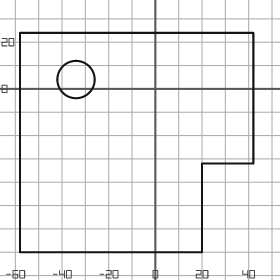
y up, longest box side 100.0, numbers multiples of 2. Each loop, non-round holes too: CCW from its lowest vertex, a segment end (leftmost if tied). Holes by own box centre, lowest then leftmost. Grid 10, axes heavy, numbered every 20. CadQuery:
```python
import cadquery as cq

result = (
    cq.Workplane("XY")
    .moveTo(-58.0, -70.0)
    .lineTo(20.0, -70.0)
    .lineTo(20.0, -32.0)
    .lineTo(42.0, -32.0)
    .lineTo(42.0, 24.0)
    .lineTo(-58.0, 24.0)
    .close()
    .moveTo(-34.0, 4.0)
    .circle(8.0)
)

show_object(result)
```